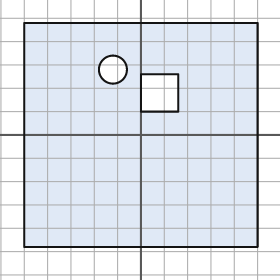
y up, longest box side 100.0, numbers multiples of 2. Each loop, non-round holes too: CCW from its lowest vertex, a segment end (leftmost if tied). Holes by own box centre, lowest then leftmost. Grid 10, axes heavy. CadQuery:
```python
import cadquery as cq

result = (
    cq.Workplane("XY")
    .moveTo(-50.0, -48.0)
    .lineTo(50.0, -48.0)
    .lineTo(50.0, 48.0)
    .lineTo(-50.0, 48.0)
    .close()
    .moveTo(0.0, 10.0)
    .lineTo(16.0, 10.0)
    .lineTo(16.0, 26.0)
    .lineTo(0.0, 26.0)
    .close()
    .moveTo(-12.0, 28.0)
    .circle(6.0)
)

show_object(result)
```